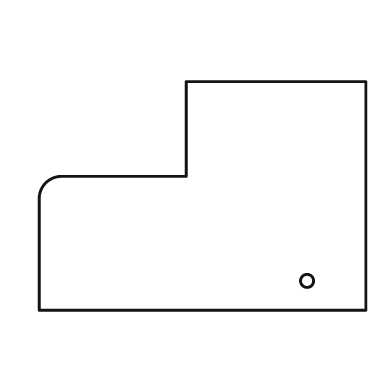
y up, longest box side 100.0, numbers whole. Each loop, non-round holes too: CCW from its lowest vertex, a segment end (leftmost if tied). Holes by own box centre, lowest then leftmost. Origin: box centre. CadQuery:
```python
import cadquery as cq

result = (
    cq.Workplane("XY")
    .moveTo(-50.0, -35.0)
    .lineTo(50.0, -35.0)
    .lineTo(50.0, 35.0)
    .lineTo(-5.0, 35.0)
    .lineTo(-5.0, 6.0)
    .lineTo(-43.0, 6.0)
    .threePointArc((-48.0, 4.0), (-50.0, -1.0))
    .close()
    .moveTo(32.0, -26.0)
    .circle(2.0)
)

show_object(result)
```